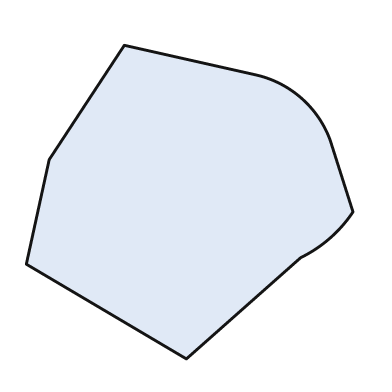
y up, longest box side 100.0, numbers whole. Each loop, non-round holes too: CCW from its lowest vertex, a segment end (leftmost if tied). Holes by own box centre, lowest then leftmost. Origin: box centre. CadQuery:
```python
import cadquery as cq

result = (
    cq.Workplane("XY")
    .moveTo(-1.0, -48.0)
    .lineTo(34.0, -17.0)
    .threePointArc((43.0, -11.0), (50.0, -3.0))
    .lineTo(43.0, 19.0)
    .threePointArc((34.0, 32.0), (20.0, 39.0))
    .lineTo(-20.0, 48.0)
    .lineTo(-43.0, 13.0)
    .lineTo(-50.0, -19.0)
    .close()
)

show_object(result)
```